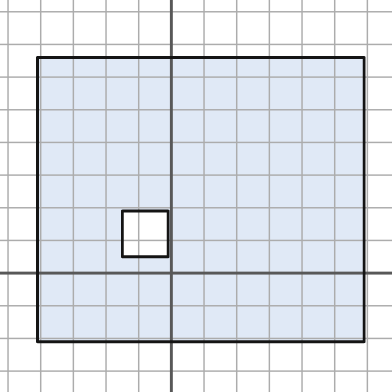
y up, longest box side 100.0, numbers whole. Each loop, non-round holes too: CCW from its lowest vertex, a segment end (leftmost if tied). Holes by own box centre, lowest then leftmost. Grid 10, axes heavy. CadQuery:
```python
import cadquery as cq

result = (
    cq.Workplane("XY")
    .moveTo(-41.0, -21.0)
    .lineTo(59.0, -21.0)
    .lineTo(59.0, 66.0)
    .lineTo(-41.0, 66.0)
    .close()
    .moveTo(-15.0, 5.0)
    .lineTo(-1.0, 5.0)
    .lineTo(-1.0, 19.0)
    .lineTo(-15.0, 19.0)
    .close()
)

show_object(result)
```